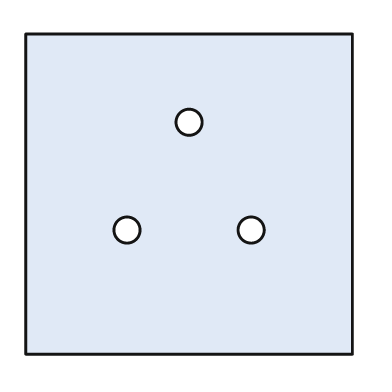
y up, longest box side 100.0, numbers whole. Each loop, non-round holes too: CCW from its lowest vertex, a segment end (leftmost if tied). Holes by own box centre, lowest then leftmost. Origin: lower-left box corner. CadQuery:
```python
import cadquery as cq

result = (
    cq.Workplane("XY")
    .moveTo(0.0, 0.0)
    .lineTo(100.0, 0.0)
    .lineTo(100.0, 98.0)
    .lineTo(0.0, 98.0)
    .close()
    .moveTo(31.0, 38.0)
    .circle(4.0)
    .moveTo(69.0, 38.0)
    .circle(4.0)
    .moveTo(50.0, 71.0)
    .circle(4.0)
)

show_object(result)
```